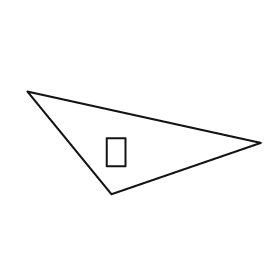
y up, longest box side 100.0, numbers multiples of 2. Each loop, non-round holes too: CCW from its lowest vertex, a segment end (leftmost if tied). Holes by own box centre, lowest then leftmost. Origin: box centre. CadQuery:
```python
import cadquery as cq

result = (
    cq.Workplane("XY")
    .moveTo(-14.0, -22.0)
    .lineTo(50.0, 0.0)
    .lineTo(-50.0, 22.0)
    .close()
    .moveTo(-16.0, -10.0)
    .lineTo(-8.0, -10.0)
    .lineTo(-8.0, 2.0)
    .lineTo(-16.0, 2.0)
    .close()
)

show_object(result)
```